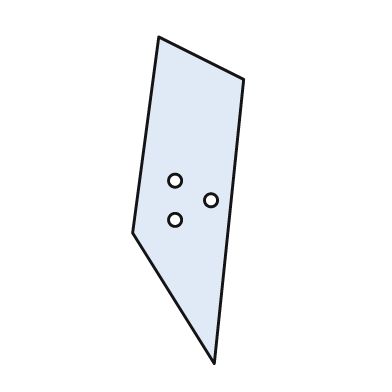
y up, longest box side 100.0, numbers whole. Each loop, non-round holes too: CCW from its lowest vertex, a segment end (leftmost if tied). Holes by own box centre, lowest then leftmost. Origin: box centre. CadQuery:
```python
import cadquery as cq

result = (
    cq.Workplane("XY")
    .moveTo(8.0, -50.0)
    .lineTo(17.0, 37.0)
    .lineTo(-9.0, 50.0)
    .lineTo(-17.0, -10.0)
    .close()
    .moveTo(-4.0, -6.0)
    .circle(2.0)
    .moveTo(7.0, 0.0)
    .circle(2.0)
    .moveTo(-4.0, 6.0)
    .circle(2.0)
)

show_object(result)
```